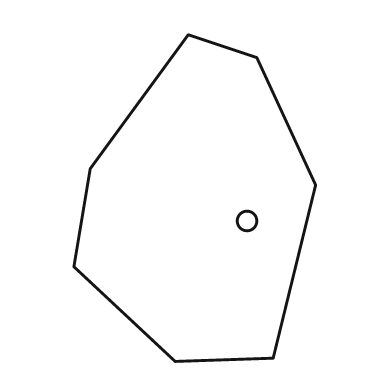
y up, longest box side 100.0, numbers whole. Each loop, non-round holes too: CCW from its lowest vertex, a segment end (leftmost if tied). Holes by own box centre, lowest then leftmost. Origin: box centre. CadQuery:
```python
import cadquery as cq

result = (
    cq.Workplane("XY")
    .moveTo(-6.0, -50.0)
    .lineTo(24.0, -49.0)
    .lineTo(37.0, 4.0)
    .lineTo(19.0, 43.0)
    .lineTo(-2.0, 50.0)
    .lineTo(-32.0, 9.0)
    .lineTo(-37.0, -21.0)
    .close()
    .moveTo(16.0, -7.0)
    .circle(3.0)
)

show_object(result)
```